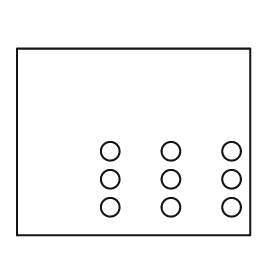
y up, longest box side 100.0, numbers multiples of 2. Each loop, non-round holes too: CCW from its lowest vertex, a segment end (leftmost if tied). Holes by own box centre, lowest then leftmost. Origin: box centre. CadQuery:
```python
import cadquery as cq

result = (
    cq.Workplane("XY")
    .moveTo(-50.0, -40.0)
    .lineTo(50.0, -40.0)
    .lineTo(50.0, 40.0)
    .lineTo(-50.0, 40.0)
    .close()
    .moveTo(-10.0, -28.0)
    .circle(4.0)
    .moveTo(16.0, -28.0)
    .circle(4.0)
    .moveTo(42.0, -28.0)
    .circle(4.0)
    .moveTo(-10.0, -16.0)
    .circle(4.0)
    .moveTo(16.0, -16.0)
    .circle(4.0)
    .moveTo(42.0, -16.0)
    .circle(4.0)
    .moveTo(-10.0, -4.0)
    .circle(4.0)
    .moveTo(16.0, -4.0)
    .circle(4.0)
    .moveTo(42.0, -4.0)
    .circle(4.0)
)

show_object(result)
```